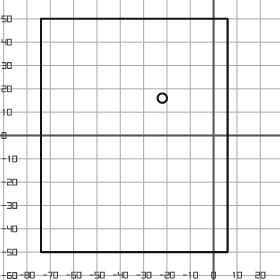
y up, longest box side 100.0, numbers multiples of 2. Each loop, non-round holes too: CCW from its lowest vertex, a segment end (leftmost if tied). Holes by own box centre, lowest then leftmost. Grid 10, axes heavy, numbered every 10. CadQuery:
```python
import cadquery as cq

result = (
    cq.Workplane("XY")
    .moveTo(-74.0, -50.0)
    .lineTo(6.0, -50.0)
    .lineTo(6.0, 50.0)
    .lineTo(-74.0, 50.0)
    .close()
    .moveTo(-22.0, 16.0)
    .circle(2.0)
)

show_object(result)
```